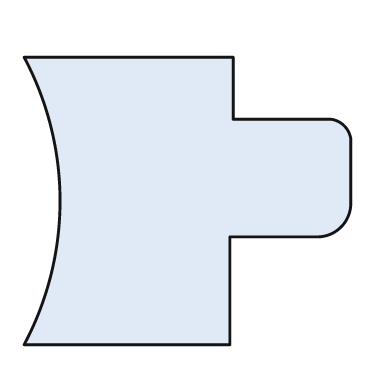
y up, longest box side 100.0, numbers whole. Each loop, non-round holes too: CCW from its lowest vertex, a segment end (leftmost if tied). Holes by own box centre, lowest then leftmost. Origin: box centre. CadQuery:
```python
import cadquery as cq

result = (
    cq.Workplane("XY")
    .moveTo(-50.0, -44.0)
    .lineTo(13.0, -44.0)
    .lineTo(13.0, -11.0)
    .lineTo(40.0, -11.0)
    .threePointArc((47.0, -8.0), (50.0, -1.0))
    .lineTo(50.0, 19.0)
    .threePointArc((48.0, 23.0), (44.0, 25.0))
    .lineTo(14.0, 25.0)
    .lineTo(14.0, 44.0)
    .lineTo(-50.0, 44.0)
    .threePointArc((-39.0, 0.0), (-50.0, -44.0))
    .close()
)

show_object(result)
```